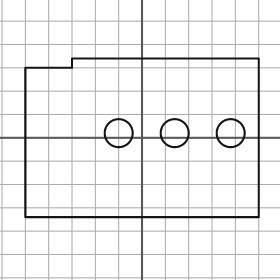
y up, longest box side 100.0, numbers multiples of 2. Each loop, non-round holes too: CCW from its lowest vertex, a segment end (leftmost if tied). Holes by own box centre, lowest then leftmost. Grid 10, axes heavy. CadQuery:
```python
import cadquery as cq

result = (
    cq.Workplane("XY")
    .moveTo(-50.0, -34.0)
    .lineTo(50.0, -34.0)
    .lineTo(50.0, 34.0)
    .lineTo(-30.0, 34.0)
    .lineTo(-30.0, 30.0)
    .lineTo(-50.0, 30.0)
    .close()
    .moveTo(-10.0, 2.0)
    .circle(6.0)
    .moveTo(14.0, 2.0)
    .circle(6.0)
    .moveTo(38.0, 2.0)
    .circle(6.0)
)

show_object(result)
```